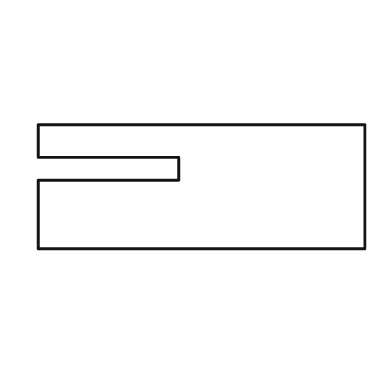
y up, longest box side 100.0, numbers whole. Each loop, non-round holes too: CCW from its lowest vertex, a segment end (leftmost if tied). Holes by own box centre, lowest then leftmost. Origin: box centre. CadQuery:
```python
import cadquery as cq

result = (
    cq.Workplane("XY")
    .moveTo(-50.0, -19.0)
    .lineTo(50.0, -19.0)
    .lineTo(50.0, 19.0)
    .lineTo(-50.0, 19.0)
    .lineTo(-50.0, 9.0)
    .lineTo(-7.0, 9.0)
    .lineTo(-7.0, 2.0)
    .lineTo(-50.0, 2.0)
    .close()
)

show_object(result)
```